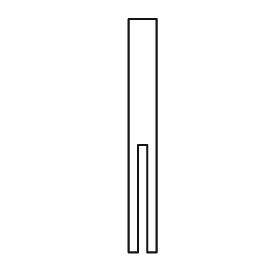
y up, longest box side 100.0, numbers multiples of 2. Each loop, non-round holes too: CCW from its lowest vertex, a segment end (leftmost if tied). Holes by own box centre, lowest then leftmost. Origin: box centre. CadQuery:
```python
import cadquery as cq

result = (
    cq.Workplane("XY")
    .moveTo(-6.0, -50.0)
    .lineTo(-2.0, -50.0)
    .lineTo(-2.0, -4.0)
    .lineTo(2.0, -4.0)
    .lineTo(2.0, -50.0)
    .lineTo(6.0, -50.0)
    .lineTo(6.0, 50.0)
    .lineTo(-6.0, 50.0)
    .close()
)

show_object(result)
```